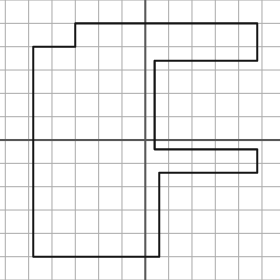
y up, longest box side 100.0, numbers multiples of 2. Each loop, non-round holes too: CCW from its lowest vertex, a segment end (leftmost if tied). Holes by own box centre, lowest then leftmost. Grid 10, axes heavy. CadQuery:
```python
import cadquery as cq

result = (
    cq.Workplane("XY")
    .moveTo(-48.0, -50.0)
    .lineTo(6.0, -50.0)
    .lineTo(6.0, -14.0)
    .lineTo(48.0, -14.0)
    .lineTo(48.0, -4.0)
    .lineTo(4.0, -4.0)
    .lineTo(4.0, 34.0)
    .lineTo(48.0, 34.0)
    .lineTo(48.0, 50.0)
    .lineTo(-30.0, 50.0)
    .lineTo(-30.0, 40.0)
    .lineTo(-48.0, 40.0)
    .close()
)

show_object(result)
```